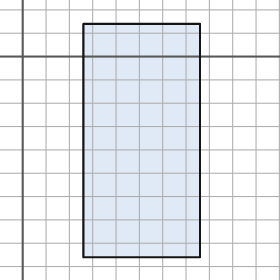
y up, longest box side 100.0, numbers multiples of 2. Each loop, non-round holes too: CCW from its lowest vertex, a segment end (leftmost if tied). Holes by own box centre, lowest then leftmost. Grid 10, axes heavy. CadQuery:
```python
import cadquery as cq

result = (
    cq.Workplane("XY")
    .moveTo(26.0, -86.0)
    .lineTo(76.0, -86.0)
    .lineTo(76.0, 14.0)
    .lineTo(26.0, 14.0)
    .close()
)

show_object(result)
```